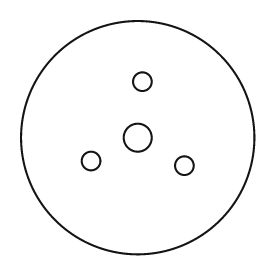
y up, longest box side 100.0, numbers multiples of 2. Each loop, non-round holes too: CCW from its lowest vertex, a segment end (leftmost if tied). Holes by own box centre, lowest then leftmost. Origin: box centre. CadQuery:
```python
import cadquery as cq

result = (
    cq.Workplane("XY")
    .moveTo(0.0, 0.0)
    .circle(50.0)
    .moveTo(20.0, -12.0)
    .circle(4.0)
    .moveTo(-20.0, -10.0)
    .circle(4.0)
    .moveTo(0.0, 0.0)
    .circle(6.0)
    .moveTo(2.0, 24.0)
    .circle(4.0)
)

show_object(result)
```